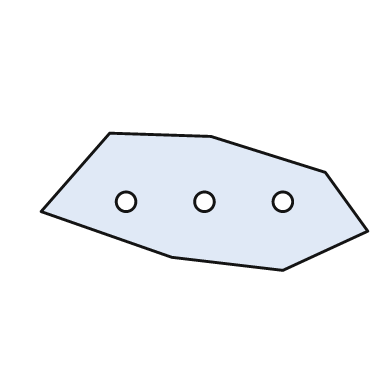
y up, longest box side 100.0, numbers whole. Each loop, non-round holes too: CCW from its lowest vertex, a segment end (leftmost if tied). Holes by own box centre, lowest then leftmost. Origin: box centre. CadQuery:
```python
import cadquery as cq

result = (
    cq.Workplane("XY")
    .moveTo(24.0, -21.0)
    .lineTo(50.0, -9.0)
    .lineTo(37.0, 9.0)
    .lineTo(2.0, 20.0)
    .lineTo(-29.0, 21.0)
    .lineTo(-50.0, -3.0)
    .lineTo(-10.0, -17.0)
    .close()
    .moveTo(-24.0, 0.0)
    .circle(3.0)
    .moveTo(0.0, 0.0)
    .circle(3.0)
    .moveTo(24.0, 0.0)
    .circle(3.0)
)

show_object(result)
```